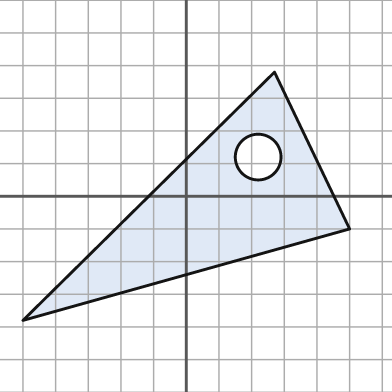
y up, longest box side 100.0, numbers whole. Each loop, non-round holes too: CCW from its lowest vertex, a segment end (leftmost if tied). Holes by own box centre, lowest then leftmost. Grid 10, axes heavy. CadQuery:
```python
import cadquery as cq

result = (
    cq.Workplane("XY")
    .moveTo(-50.0, -38.0)
    .lineTo(50.0, -10.0)
    .lineTo(27.0, 38.0)
    .close()
    .moveTo(22.0, 12.0)
    .circle(7.0)
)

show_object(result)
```